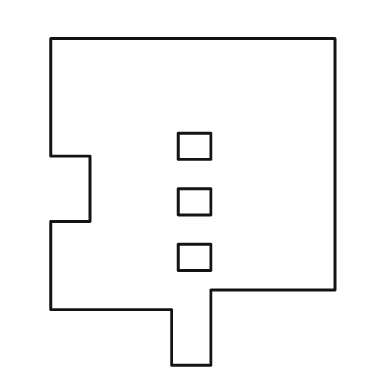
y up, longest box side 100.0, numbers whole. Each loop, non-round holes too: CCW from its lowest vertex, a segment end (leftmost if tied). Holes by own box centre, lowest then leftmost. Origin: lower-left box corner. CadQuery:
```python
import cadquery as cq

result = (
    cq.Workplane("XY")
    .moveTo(37.0, 0.0)
    .lineTo(49.0, 0.0)
    .lineTo(49.0, 23.0)
    .lineTo(87.0, 23.0)
    .lineTo(87.0, 100.0)
    .lineTo(0.0, 100.0)
    .lineTo(0.0, 64.0)
    .lineTo(12.0, 64.0)
    .lineTo(12.0, 44.0)
    .lineTo(0.0, 44.0)
    .lineTo(0.0, 17.0)
    .lineTo(37.0, 17.0)
    .close()
    .moveTo(39.0, 29.0)
    .lineTo(49.0, 29.0)
    .lineTo(49.0, 37.0)
    .lineTo(39.0, 37.0)
    .close()
    .moveTo(39.0, 46.0)
    .lineTo(49.0, 46.0)
    .lineTo(49.0, 54.0)
    .lineTo(39.0, 54.0)
    .close()
    .moveTo(39.0, 63.0)
    .lineTo(49.0, 63.0)
    .lineTo(49.0, 71.0)
    .lineTo(39.0, 71.0)
    .close()
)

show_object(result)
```